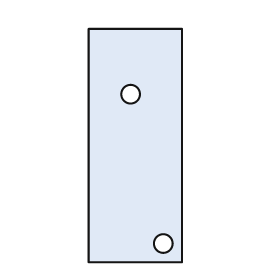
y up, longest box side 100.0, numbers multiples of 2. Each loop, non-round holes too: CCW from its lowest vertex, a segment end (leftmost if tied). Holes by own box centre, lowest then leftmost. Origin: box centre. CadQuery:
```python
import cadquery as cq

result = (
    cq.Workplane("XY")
    .moveTo(-20.0, -50.0)
    .lineTo(20.0, -50.0)
    .lineTo(20.0, 50.0)
    .lineTo(-20.0, 50.0)
    .close()
    .moveTo(12.0, -42.0)
    .circle(4.0)
    .moveTo(-2.0, 22.0)
    .circle(4.0)
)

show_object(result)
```